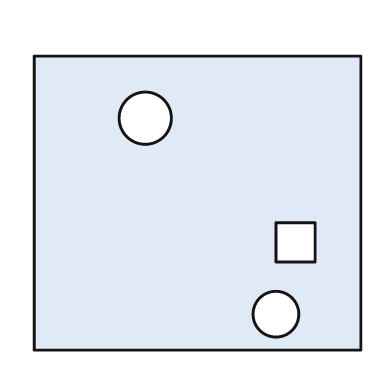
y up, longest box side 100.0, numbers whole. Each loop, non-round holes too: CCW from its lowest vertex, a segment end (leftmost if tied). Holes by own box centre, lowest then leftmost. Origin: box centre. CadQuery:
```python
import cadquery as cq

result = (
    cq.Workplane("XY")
    .moveTo(-50.0, -45.0)
    .lineTo(50.0, -45.0)
    .lineTo(50.0, 45.0)
    .lineTo(-50.0, 45.0)
    .close()
    .moveTo(24.0, -34.0)
    .circle(7.0)
    .moveTo(24.0, -18.0)
    .lineTo(36.0, -18.0)
    .lineTo(36.0, -6.0)
    .lineTo(24.0, -6.0)
    .close()
    .moveTo(-16.0, 26.0)
    .circle(8.0)
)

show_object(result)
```